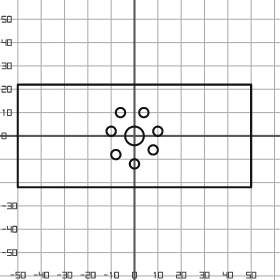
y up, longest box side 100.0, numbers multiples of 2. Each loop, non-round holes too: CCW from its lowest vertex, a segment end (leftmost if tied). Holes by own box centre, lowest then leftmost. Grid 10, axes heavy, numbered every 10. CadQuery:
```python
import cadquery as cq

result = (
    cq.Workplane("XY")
    .moveTo(-50.0, -22.0)
    .lineTo(50.0, -22.0)
    .lineTo(50.0, 22.0)
    .lineTo(-50.0, 22.0)
    .close()
    .moveTo(0.0, -12.0)
    .circle(2.0)
    .moveTo(-8.0, -8.0)
    .circle(2.0)
    .moveTo(8.0, -6.0)
    .circle(2.0)
    .moveTo(0.0, 0.0)
    .circle(4.0)
    .moveTo(-10.0, 2.0)
    .circle(2.0)
    .moveTo(10.0, 2.0)
    .circle(2.0)
    .moveTo(-6.0, 10.0)
    .circle(2.0)
    .moveTo(4.0, 10.0)
    .circle(2.0)
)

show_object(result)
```